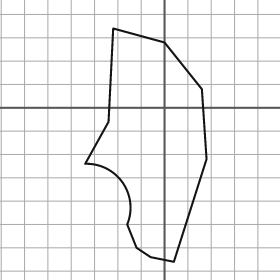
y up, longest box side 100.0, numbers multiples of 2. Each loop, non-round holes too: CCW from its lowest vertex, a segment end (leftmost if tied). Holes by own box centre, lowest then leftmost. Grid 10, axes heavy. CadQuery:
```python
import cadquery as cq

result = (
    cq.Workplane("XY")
    .moveTo(4.0, -66.0)
    .lineTo(18.0, -22.0)
    .lineTo(16.0, 8.0)
    .lineTo(0.0, 28.0)
    .lineTo(-22.0, 34.0)
    .lineTo(-24.0, -6.0)
    .lineTo(-34.0, -24.0)
    .threePointArc((-18.0, -32.0), (-16.0, -50.0))
    .lineTo(-12.0, -60.0)
    .lineTo(-6.0, -64.0)
    .close()
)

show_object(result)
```